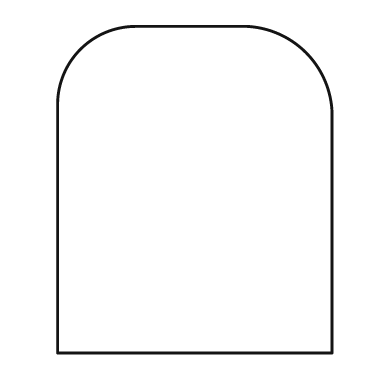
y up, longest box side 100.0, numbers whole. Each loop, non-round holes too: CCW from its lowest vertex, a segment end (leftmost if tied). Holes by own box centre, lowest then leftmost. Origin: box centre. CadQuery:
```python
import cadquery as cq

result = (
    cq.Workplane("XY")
    .moveTo(-42.0, -50.0)
    .lineTo(42.0, -50.0)
    .lineTo(42.0, 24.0)
    .threePointArc((34.0, 42.0), (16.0, 50.0))
    .lineTo(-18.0, 50.0)
    .threePointArc((-35.0, 43.0), (-42.0, 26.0))
    .close()
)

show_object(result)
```